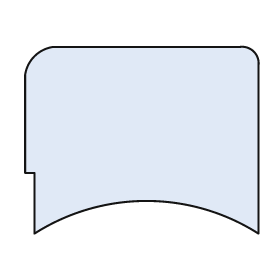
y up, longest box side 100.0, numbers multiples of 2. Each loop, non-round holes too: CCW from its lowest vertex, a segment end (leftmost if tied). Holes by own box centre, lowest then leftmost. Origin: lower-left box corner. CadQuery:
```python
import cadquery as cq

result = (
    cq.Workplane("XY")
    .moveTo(4.0, 0.0)
    .threePointArc((52.0, 14.0), (100.0, 0.0))
    .lineTo(100.0, 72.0)
    .threePointArc((98.0, 78.0), (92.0, 80.0))
    .lineTo(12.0, 80.0)
    .threePointArc((4.0, 76.0), (0.0, 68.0))
    .lineTo(0.0, 26.0)
    .lineTo(4.0, 26.0)
    .close()
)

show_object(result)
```